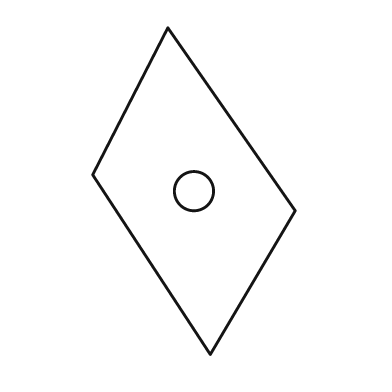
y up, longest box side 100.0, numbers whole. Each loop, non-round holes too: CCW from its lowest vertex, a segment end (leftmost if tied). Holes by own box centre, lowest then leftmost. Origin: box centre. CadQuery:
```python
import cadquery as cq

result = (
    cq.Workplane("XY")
    .moveTo(5.0, -50.0)
    .lineTo(31.0, -6.0)
    .lineTo(-8.0, 50.0)
    .lineTo(-31.0, 5.0)
    .close()
    .moveTo(0.0, 0.0)
    .circle(6.0)
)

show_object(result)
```